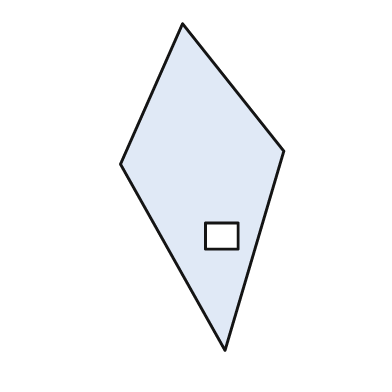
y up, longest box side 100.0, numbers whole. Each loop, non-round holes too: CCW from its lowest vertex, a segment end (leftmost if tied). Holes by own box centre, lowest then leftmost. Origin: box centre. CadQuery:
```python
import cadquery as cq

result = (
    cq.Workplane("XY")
    .moveTo(7.0, -50.0)
    .lineTo(25.0, 11.0)
    .lineTo(-6.0, 50.0)
    .lineTo(-25.0, 7.0)
    .close()
    .moveTo(1.0, -19.0)
    .lineTo(11.0, -19.0)
    .lineTo(11.0, -11.0)
    .lineTo(1.0, -11.0)
    .close()
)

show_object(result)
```